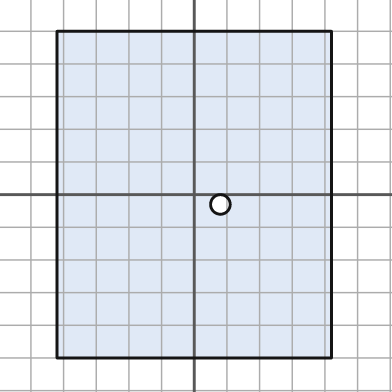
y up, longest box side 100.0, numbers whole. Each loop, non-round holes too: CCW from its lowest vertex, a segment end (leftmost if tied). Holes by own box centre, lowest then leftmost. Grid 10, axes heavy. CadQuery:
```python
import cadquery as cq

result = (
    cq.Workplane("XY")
    .moveTo(-42.0, -50.0)
    .lineTo(42.0, -50.0)
    .lineTo(42.0, 50.0)
    .lineTo(-42.0, 50.0)
    .close()
    .moveTo(8.0, -3.0)
    .circle(3.0)
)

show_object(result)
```